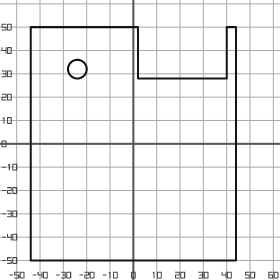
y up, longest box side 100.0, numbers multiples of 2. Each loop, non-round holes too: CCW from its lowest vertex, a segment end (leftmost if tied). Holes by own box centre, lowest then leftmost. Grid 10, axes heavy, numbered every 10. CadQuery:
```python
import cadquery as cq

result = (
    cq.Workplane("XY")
    .moveTo(-44.0, -50.0)
    .lineTo(44.0, -50.0)
    .lineTo(44.0, 50.0)
    .lineTo(40.0, 50.0)
    .lineTo(40.0, 28.0)
    .lineTo(2.0, 28.0)
    .lineTo(2.0, 50.0)
    .lineTo(-44.0, 50.0)
    .close()
    .moveTo(-24.0, 32.0)
    .circle(4.0)
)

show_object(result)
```